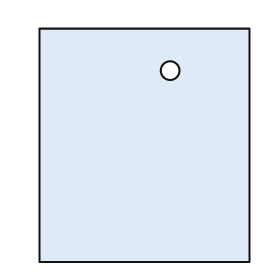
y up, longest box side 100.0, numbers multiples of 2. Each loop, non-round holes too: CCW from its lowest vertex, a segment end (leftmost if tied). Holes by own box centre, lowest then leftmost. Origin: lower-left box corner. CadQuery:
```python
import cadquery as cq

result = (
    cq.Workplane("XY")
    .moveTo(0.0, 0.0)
    .lineTo(90.0, 0.0)
    .lineTo(90.0, 100.0)
    .lineTo(0.0, 100.0)
    .close()
    .moveTo(56.0, 82.0)
    .circle(4.0)
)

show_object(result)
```